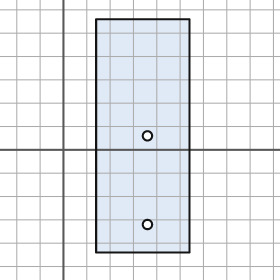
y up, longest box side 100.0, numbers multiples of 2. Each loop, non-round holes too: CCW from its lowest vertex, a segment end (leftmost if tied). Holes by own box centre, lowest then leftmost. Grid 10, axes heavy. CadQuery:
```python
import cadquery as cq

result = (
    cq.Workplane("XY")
    .moveTo(14.0, -44.0)
    .lineTo(54.0, -44.0)
    .lineTo(54.0, 56.0)
    .lineTo(14.0, 56.0)
    .close()
    .moveTo(36.0, -32.0)
    .circle(2.0)
    .moveTo(36.0, 6.0)
    .circle(2.0)
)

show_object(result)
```